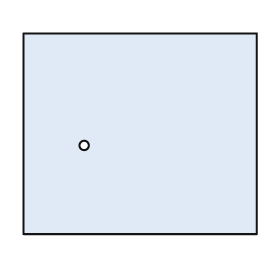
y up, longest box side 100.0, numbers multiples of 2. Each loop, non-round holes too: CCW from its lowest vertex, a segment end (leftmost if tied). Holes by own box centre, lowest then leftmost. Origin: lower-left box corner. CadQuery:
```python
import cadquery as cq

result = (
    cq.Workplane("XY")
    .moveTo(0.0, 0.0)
    .lineTo(100.0, 0.0)
    .lineTo(100.0, 86.0)
    .lineTo(0.0, 86.0)
    .close()
    .moveTo(26.0, 38.0)
    .circle(2.0)
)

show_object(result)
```